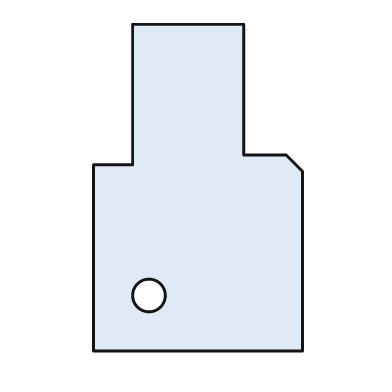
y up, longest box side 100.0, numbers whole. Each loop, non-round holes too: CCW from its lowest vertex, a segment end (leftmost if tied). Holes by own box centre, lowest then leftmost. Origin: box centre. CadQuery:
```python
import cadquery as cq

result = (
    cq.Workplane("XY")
    .moveTo(-32.0, -50.0)
    .lineTo(32.0, -50.0)
    .lineTo(32.0, 5.0)
    .lineTo(27.0, 10.0)
    .lineTo(14.0, 10.0)
    .lineTo(14.0, 50.0)
    .lineTo(-20.0, 50.0)
    .lineTo(-20.0, 7.0)
    .lineTo(-32.0, 7.0)
    .close()
    .moveTo(-15.0, -33.0)
    .circle(5.0)
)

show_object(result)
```